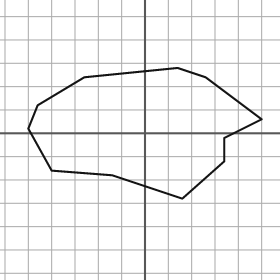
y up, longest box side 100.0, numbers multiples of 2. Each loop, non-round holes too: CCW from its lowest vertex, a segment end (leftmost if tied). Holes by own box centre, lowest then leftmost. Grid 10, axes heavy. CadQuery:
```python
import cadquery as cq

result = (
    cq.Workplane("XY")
    .moveTo(16.0, -28.0)
    .lineTo(34.0, -12.0)
    .lineTo(34.0, -2.0)
    .lineTo(50.0, 6.0)
    .lineTo(26.0, 24.0)
    .lineTo(14.0, 28.0)
    .lineTo(-26.0, 24.0)
    .lineTo(-46.0, 12.0)
    .lineTo(-50.0, 2.0)
    .lineTo(-40.0, -16.0)
    .lineTo(-14.0, -18.0)
    .close()
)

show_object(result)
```